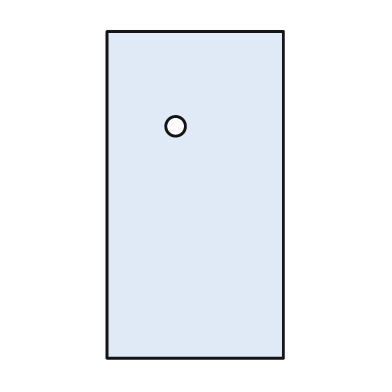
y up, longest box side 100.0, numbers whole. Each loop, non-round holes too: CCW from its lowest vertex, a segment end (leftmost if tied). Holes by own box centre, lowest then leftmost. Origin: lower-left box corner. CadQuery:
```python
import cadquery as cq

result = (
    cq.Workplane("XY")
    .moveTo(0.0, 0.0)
    .lineTo(54.0, 0.0)
    .lineTo(54.0, 100.0)
    .lineTo(0.0, 100.0)
    .close()
    .moveTo(21.0, 71.0)
    .circle(3.0)
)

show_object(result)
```